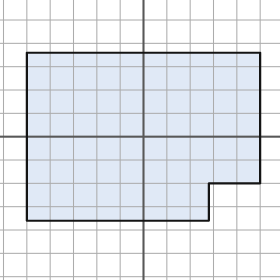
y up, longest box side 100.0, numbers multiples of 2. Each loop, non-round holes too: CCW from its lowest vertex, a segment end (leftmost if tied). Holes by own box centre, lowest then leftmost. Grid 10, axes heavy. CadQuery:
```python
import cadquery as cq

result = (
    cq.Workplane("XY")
    .moveTo(-50.0, -36.0)
    .lineTo(28.0, -36.0)
    .lineTo(28.0, -20.0)
    .lineTo(50.0, -20.0)
    .lineTo(50.0, 36.0)
    .lineTo(-50.0, 36.0)
    .close()
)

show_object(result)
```